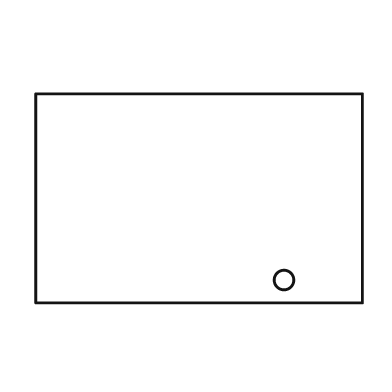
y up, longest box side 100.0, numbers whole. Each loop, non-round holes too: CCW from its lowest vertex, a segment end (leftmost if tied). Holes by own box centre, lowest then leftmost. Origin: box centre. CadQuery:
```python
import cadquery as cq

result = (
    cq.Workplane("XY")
    .moveTo(-50.0, -32.0)
    .lineTo(50.0, -32.0)
    .lineTo(50.0, 32.0)
    .lineTo(-50.0, 32.0)
    .close()
    .moveTo(26.0, -25.0)
    .circle(3.0)
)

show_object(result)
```